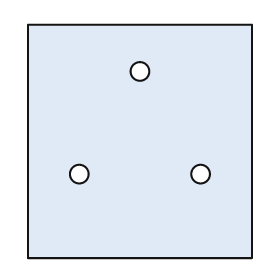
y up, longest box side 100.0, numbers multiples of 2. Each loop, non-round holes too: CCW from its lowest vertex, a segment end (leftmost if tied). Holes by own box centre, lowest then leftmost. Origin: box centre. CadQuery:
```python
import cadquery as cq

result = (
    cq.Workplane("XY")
    .moveTo(-48.0, -50.0)
    .lineTo(48.0, -50.0)
    .lineTo(48.0, 50.0)
    .lineTo(-48.0, 50.0)
    .close()
    .moveTo(-26.0, -14.0)
    .circle(4.0)
    .moveTo(26.0, -14.0)
    .circle(4.0)
    .moveTo(0.0, 30.0)
    .circle(4.0)
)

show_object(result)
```